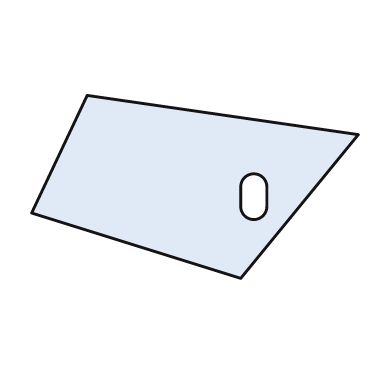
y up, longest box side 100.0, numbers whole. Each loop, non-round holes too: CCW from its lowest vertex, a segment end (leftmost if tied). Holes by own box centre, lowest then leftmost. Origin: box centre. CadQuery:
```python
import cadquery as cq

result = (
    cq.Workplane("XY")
    .moveTo(14.0, -28.0)
    .lineTo(50.0, 16.0)
    .lineTo(-33.0, 28.0)
    .lineTo(-50.0, -8.0)
    .close()
    .moveTo(14.0, -6.0)
    .threePointArc((18.0, -10.0), (22.0, -6.0))
    .lineTo(22.0, 0.0)
    .threePointArc((18.0, 4.0), (14.0, 0.0))
    .close()
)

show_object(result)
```